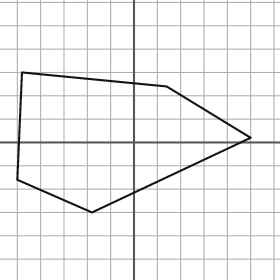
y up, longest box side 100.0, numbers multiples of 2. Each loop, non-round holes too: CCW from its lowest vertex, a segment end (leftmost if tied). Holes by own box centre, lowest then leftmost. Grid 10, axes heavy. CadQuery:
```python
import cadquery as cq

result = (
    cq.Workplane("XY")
    .moveTo(-18.0, -30.0)
    .lineTo(50.0, 2.0)
    .lineTo(14.0, 24.0)
    .lineTo(-48.0, 30.0)
    .lineTo(-50.0, -16.0)
    .close()
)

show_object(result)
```